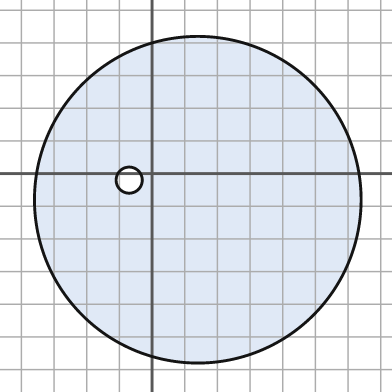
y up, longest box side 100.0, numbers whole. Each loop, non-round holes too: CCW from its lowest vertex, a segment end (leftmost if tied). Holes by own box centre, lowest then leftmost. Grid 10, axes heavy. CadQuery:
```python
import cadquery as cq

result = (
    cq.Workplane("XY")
    .moveTo(14.0, -8.0)
    .circle(50.0)
    .moveTo(-7.0, -2.0)
    .circle(4.0)
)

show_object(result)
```